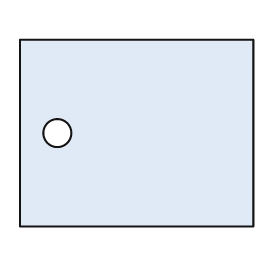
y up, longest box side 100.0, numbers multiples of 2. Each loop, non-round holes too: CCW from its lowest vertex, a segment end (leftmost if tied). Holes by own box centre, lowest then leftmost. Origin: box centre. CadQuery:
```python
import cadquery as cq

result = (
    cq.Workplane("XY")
    .moveTo(-50.0, -40.0)
    .lineTo(50.0, -40.0)
    .lineTo(50.0, 40.0)
    .lineTo(-50.0, 40.0)
    .close()
    .moveTo(-34.0, 0.0)
    .circle(6.0)
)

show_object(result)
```